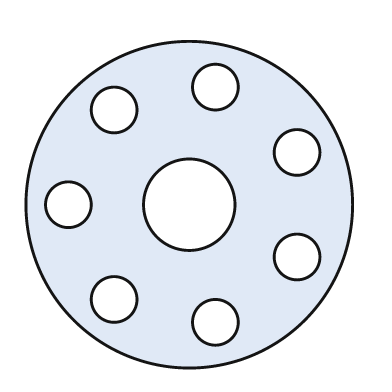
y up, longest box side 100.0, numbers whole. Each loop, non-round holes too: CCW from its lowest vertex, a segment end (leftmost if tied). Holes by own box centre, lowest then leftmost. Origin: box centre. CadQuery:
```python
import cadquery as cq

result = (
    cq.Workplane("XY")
    .moveTo(0.0, 0.0)
    .circle(50.0)
    .moveTo(8.0, -36.0)
    .circle(7.0)
    .moveTo(-23.0, -29.0)
    .circle(7.0)
    .moveTo(33.0, -16.0)
    .circle(7.0)
    .moveTo(-37.0, 0.0)
    .circle(7.0)
    .moveTo(0.0, 0.0)
    .circle(14.0)
    .moveTo(33.0, 16.0)
    .circle(7.0)
    .moveTo(-23.0, 29.0)
    .circle(7.0)
    .moveTo(8.0, 36.0)
    .circle(7.0)
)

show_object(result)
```